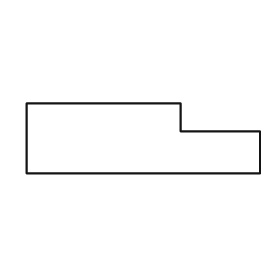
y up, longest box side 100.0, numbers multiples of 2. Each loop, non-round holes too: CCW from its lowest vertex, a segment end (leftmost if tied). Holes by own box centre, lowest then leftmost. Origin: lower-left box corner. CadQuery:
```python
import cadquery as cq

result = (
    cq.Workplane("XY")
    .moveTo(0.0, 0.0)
    .lineTo(100.0, 0.0)
    .lineTo(100.0, 18.0)
    .lineTo(66.0, 18.0)
    .lineTo(66.0, 30.0)
    .lineTo(0.0, 30.0)
    .close()
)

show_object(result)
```